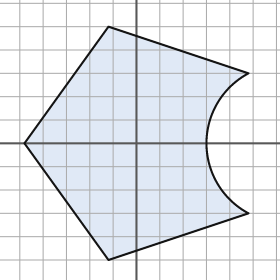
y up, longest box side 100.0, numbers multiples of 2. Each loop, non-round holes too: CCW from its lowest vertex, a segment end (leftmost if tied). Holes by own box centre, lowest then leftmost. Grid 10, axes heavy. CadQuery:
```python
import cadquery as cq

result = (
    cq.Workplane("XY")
    .moveTo(-12.0, -50.0)
    .lineTo(48.0, -30.0)
    .threePointArc((30.0, 0.0), (48.0, 30.0))
    .lineTo(-12.0, 50.0)
    .lineTo(-48.0, 0.0)
    .close()
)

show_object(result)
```